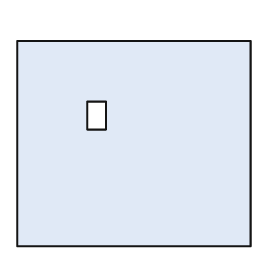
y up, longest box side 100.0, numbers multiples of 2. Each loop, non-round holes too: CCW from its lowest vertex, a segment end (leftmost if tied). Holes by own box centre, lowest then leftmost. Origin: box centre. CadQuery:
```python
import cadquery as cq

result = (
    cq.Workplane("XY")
    .moveTo(-50.0, -44.0)
    .lineTo(50.0, -44.0)
    .lineTo(50.0, 44.0)
    .lineTo(-50.0, 44.0)
    .close()
    .moveTo(-20.0, 6.0)
    .lineTo(-12.0, 6.0)
    .lineTo(-12.0, 18.0)
    .lineTo(-20.0, 18.0)
    .close()
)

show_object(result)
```